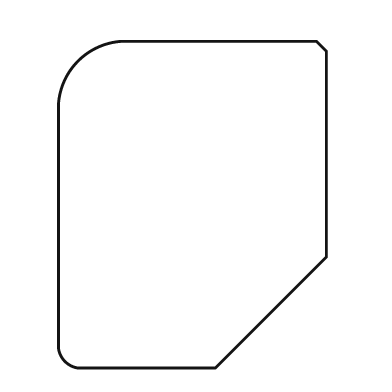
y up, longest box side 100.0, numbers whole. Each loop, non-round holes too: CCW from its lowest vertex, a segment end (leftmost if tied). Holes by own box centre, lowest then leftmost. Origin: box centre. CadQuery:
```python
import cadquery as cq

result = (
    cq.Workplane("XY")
    .moveTo(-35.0, -50.0)
    .lineTo(7.0, -50.0)
    .lineTo(41.0, -16.0)
    .lineTo(41.0, 47.0)
    .lineTo(38.0, 50.0)
    .lineTo(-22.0, 50.0)
    .threePointArc((-35.0, 44.0), (-41.0, 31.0))
    .lineTo(-41.0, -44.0)
    .threePointArc((-39.0, -48.0), (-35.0, -50.0))
    .close()
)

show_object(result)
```